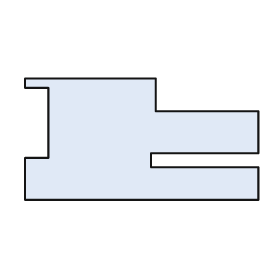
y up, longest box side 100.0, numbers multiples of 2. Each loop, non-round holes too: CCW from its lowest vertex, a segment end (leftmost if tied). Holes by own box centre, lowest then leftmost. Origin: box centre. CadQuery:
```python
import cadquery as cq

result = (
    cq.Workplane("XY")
    .moveTo(-50.0, -26.0)
    .lineTo(50.0, -26.0)
    .lineTo(50.0, -12.0)
    .lineTo(4.0, -12.0)
    .lineTo(4.0, -6.0)
    .lineTo(50.0, -6.0)
    .lineTo(50.0, 12.0)
    .lineTo(6.0, 12.0)
    .lineTo(6.0, 26.0)
    .lineTo(-50.0, 26.0)
    .lineTo(-50.0, 22.0)
    .lineTo(-40.0, 22.0)
    .lineTo(-40.0, -8.0)
    .lineTo(-50.0, -8.0)
    .close()
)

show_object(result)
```